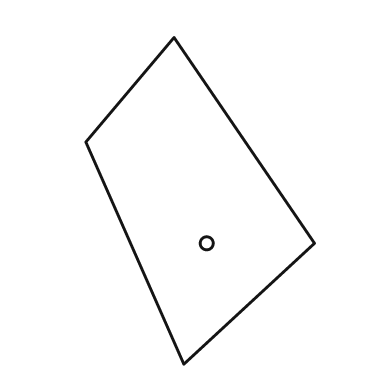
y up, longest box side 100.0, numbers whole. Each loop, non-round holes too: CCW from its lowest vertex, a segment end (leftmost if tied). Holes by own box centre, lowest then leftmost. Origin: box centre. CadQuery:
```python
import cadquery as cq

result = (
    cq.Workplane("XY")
    .moveTo(-5.0, -50.0)
    .lineTo(35.0, -13.0)
    .lineTo(-8.0, 50.0)
    .lineTo(-35.0, 18.0)
    .close()
    .moveTo(2.0, -13.0)
    .circle(2.0)
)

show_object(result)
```